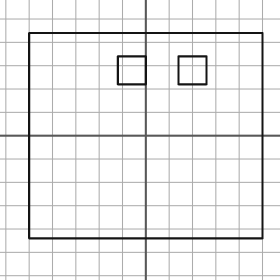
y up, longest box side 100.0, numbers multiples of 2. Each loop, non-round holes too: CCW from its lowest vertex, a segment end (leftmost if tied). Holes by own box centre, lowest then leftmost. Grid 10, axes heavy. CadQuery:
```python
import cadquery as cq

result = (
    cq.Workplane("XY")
    .moveTo(-50.0, -44.0)
    .lineTo(50.0, -44.0)
    .lineTo(50.0, 44.0)
    .lineTo(-50.0, 44.0)
    .close()
    .moveTo(-12.0, 22.0)
    .lineTo(0.0, 22.0)
    .lineTo(0.0, 34.0)
    .lineTo(-12.0, 34.0)
    .close()
    .moveTo(14.0, 22.0)
    .lineTo(26.0, 22.0)
    .lineTo(26.0, 34.0)
    .lineTo(14.0, 34.0)
    .close()
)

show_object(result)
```